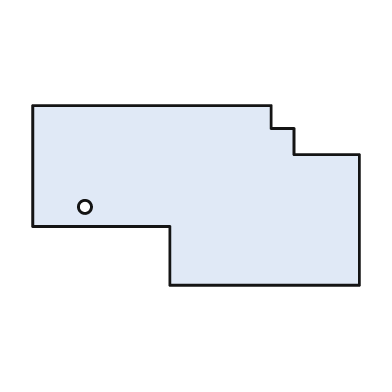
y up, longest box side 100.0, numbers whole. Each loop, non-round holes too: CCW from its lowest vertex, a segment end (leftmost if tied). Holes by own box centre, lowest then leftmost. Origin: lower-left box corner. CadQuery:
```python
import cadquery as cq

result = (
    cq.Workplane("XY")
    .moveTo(42.0, 0.0)
    .lineTo(100.0, 0.0)
    .lineTo(100.0, 40.0)
    .lineTo(80.0, 40.0)
    .lineTo(80.0, 48.0)
    .lineTo(73.0, 48.0)
    .lineTo(73.0, 55.0)
    .lineTo(0.0, 55.0)
    .lineTo(0.0, 18.0)
    .lineTo(42.0, 18.0)
    .close()
    .moveTo(16.0, 24.0)
    .circle(2.0)
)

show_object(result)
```